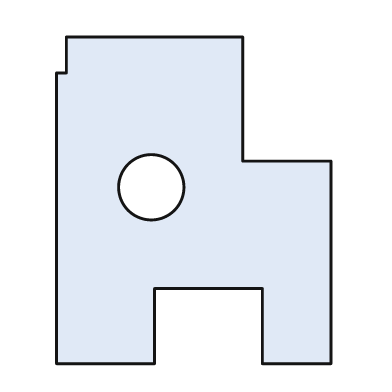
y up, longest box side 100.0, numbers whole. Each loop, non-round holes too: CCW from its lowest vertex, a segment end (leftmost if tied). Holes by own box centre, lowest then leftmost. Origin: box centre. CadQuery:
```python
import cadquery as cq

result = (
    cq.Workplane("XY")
    .moveTo(-42.0, -50.0)
    .lineTo(-12.0, -50.0)
    .lineTo(-12.0, -27.0)
    .lineTo(21.0, -27.0)
    .lineTo(21.0, -50.0)
    .lineTo(42.0, -50.0)
    .lineTo(42.0, 12.0)
    .lineTo(15.0, 12.0)
    .lineTo(15.0, 50.0)
    .lineTo(-39.0, 50.0)
    .lineTo(-39.0, 39.0)
    .lineTo(-42.0, 39.0)
    .close()
    .moveTo(-13.0, 4.0)
    .circle(10.0)
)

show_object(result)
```